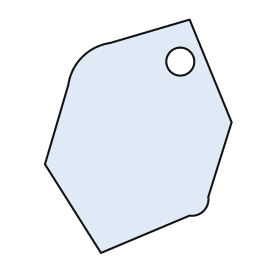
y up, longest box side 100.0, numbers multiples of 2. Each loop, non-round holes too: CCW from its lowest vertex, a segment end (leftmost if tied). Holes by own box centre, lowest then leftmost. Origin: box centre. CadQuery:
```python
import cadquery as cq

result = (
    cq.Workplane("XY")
    .moveTo(-16.0, -50.0)
    .lineTo(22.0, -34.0)
    .threePointArc((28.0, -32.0), (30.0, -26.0))
    .lineTo(40.0, 6.0)
    .lineTo(22.0, 50.0)
    .lineTo(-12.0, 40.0)
    .threePointArc((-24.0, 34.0), (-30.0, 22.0))
    .lineTo(-40.0, -12.0)
    .close()
    .moveTo(18.0, 32.0)
    .circle(6.0)
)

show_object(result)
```